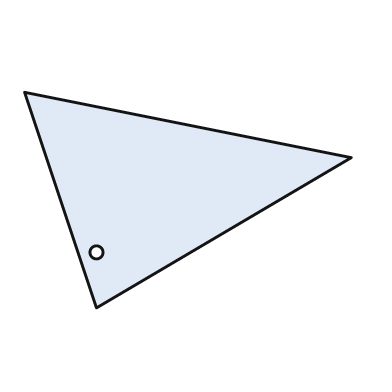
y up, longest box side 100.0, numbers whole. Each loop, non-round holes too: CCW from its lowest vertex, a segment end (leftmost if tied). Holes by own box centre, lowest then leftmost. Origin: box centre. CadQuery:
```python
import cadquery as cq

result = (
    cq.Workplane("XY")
    .moveTo(-28.0, -33.0)
    .lineTo(50.0, 13.0)
    .lineTo(-50.0, 33.0)
    .close()
    .moveTo(-28.0, -16.0)
    .circle(2.0)
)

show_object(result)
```